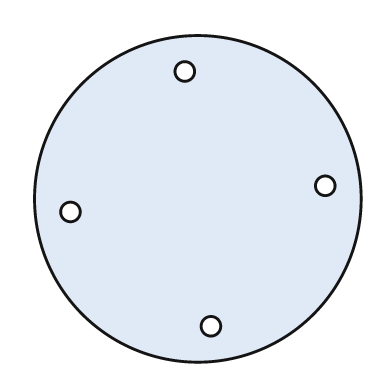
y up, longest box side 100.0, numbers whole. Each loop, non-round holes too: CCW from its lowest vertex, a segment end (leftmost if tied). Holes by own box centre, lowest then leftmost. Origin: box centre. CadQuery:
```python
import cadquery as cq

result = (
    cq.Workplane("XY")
    .moveTo(0.0, 0.0)
    .circle(50.0)
    .moveTo(4.0, -39.0)
    .circle(3.0)
    .moveTo(-39.0, -4.0)
    .circle(3.0)
    .moveTo(39.0, 4.0)
    .circle(3.0)
    .moveTo(-4.0, 39.0)
    .circle(3.0)
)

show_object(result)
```